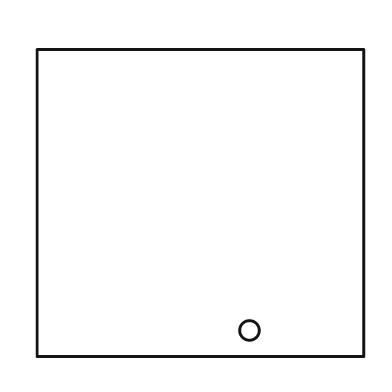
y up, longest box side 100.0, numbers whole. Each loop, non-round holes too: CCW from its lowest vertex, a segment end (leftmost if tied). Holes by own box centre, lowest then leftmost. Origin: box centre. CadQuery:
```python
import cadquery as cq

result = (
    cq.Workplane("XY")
    .moveTo(-50.0, -47.0)
    .lineTo(50.0, -47.0)
    .lineTo(50.0, 47.0)
    .lineTo(-50.0, 47.0)
    .close()
    .moveTo(15.0, -39.0)
    .circle(3.0)
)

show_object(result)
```